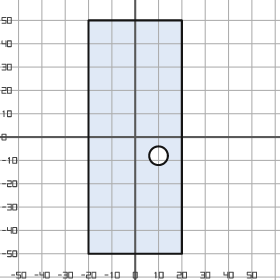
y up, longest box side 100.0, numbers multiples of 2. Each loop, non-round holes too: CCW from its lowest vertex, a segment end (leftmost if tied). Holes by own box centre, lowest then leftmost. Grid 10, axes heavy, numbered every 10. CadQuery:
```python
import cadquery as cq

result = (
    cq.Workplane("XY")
    .moveTo(-20.0, -50.0)
    .lineTo(20.0, -50.0)
    .lineTo(20.0, 50.0)
    .lineTo(-20.0, 50.0)
    .close()
    .moveTo(10.0, -8.0)
    .circle(4.0)
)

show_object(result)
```